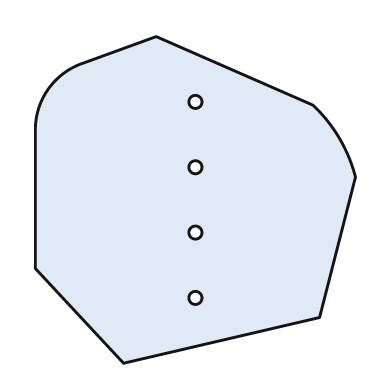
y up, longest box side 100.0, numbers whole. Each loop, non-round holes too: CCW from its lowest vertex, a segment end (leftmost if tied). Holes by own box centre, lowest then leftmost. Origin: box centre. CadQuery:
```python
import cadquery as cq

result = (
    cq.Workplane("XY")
    .moveTo(-22.0, -50.0)
    .lineTo(38.0, -36.0)
    .lineTo(49.0, 7.0)
    .threePointArc((44.0, 19.0), (36.0, 29.0))
    .lineTo(-12.0, 50.0)
    .lineTo(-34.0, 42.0)
    .threePointArc((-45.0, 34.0), (-49.0, 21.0))
    .lineTo(-49.0, -21.0)
    .close()
    .moveTo(0.0, -30.0)
    .circle(2.0)
    .moveTo(0.0, -10.0)
    .circle(2.0)
    .moveTo(0.0, 10.0)
    .circle(2.0)
    .moveTo(0.0, 30.0)
    .circle(2.0)
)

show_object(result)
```